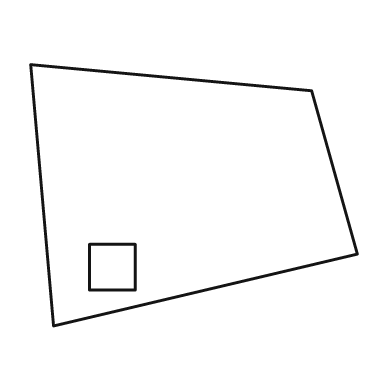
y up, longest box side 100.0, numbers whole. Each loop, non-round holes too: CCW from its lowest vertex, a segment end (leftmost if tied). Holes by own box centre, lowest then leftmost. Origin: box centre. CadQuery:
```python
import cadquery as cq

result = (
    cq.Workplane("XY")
    .moveTo(-43.0, -40.0)
    .lineTo(50.0, -18.0)
    .lineTo(36.0, 32.0)
    .lineTo(-50.0, 40.0)
    .close()
    .moveTo(-32.0, -29.0)
    .lineTo(-18.0, -29.0)
    .lineTo(-18.0, -15.0)
    .lineTo(-32.0, -15.0)
    .close()
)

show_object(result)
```